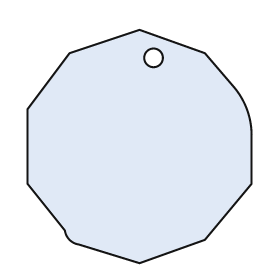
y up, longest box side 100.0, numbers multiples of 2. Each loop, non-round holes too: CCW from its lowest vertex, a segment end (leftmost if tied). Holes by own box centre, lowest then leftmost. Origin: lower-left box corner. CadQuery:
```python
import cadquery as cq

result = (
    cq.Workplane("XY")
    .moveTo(48.0, 0.0)
    .lineTo(76.0, 10.0)
    .lineTo(96.0, 34.0)
    .lineTo(96.0, 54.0)
    .threePointArc((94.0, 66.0), (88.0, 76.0))
    .lineTo(76.0, 90.0)
    .lineTo(48.0, 100.0)
    .lineTo(18.0, 90.0)
    .lineTo(0.0, 66.0)
    .lineTo(0.0, 34.0)
    .lineTo(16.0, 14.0)
    .threePointArc((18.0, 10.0), (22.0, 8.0))
    .close()
    .moveTo(54.0, 88.0)
    .circle(4.0)
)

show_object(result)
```